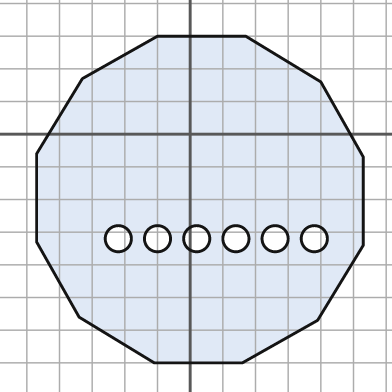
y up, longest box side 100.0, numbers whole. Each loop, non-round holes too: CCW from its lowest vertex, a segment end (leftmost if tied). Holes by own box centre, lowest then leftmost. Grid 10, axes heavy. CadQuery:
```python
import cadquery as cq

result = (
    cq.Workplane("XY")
    .moveTo(-11.0, -70.0)
    .lineTo(16.0, -70.0)
    .lineTo(39.0, -57.0)
    .lineTo(53.0, -34.0)
    .lineTo(53.0, -7.0)
    .lineTo(40.0, 16.0)
    .lineTo(17.0, 30.0)
    .lineTo(-10.0, 30.0)
    .lineTo(-33.0, 17.0)
    .lineTo(-47.0, -6.0)
    .lineTo(-47.0, -33.0)
    .lineTo(-34.0, -56.0)
    .close()
    .moveTo(-22.0, -32.0)
    .circle(4.0)
    .moveTo(-10.0, -32.0)
    .circle(4.0)
    .moveTo(2.0, -32.0)
    .circle(4.0)
    .moveTo(14.0, -32.0)
    .circle(4.0)
    .moveTo(26.0, -32.0)
    .circle(4.0)
    .moveTo(38.0, -32.0)
    .circle(4.0)
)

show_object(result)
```